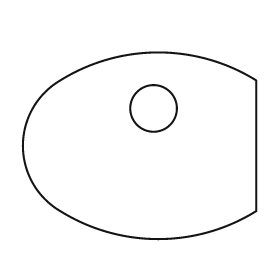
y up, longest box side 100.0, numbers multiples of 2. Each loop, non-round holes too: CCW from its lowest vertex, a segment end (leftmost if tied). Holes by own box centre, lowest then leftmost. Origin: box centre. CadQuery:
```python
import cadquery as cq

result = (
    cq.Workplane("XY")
    .moveTo(-34.0, -28.0)
    .threePointArc((8.0, -40.0), (50.0, -28.0))
    .lineTo(50.0, 28.0)
    .threePointArc((8.0, 40.0), (-34.0, 28.0))
    .threePointArc((-50.0, 0.0), (-34.0, -28.0))
    .close()
    .moveTo(6.0, 16.0)
    .circle(10.0)
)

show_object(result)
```